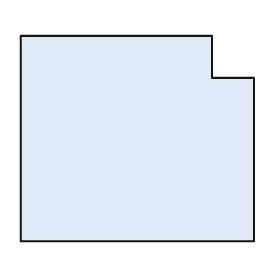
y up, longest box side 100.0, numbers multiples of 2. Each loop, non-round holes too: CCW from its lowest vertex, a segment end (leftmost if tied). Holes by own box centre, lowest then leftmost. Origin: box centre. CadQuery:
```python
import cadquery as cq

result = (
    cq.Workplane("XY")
    .moveTo(-50.0, -44.0)
    .lineTo(50.0, -44.0)
    .lineTo(50.0, 26.0)
    .lineTo(32.0, 26.0)
    .lineTo(32.0, 44.0)
    .lineTo(-50.0, 44.0)
    .close()
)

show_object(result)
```